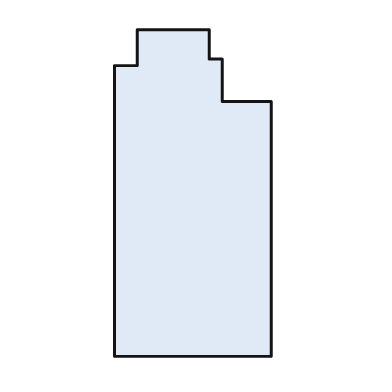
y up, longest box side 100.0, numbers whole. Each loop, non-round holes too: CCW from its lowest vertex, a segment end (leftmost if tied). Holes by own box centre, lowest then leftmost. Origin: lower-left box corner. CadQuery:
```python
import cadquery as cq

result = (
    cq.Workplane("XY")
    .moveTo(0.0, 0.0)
    .lineTo(48.0, 0.0)
    .lineTo(48.0, 78.0)
    .lineTo(33.0, 78.0)
    .lineTo(33.0, 91.0)
    .lineTo(29.0, 91.0)
    .lineTo(29.0, 100.0)
    .lineTo(7.0, 100.0)
    .lineTo(7.0, 89.0)
    .lineTo(0.0, 89.0)
    .close()
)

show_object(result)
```